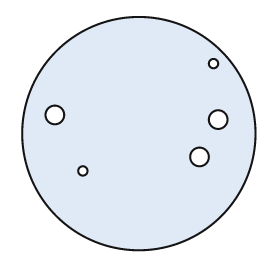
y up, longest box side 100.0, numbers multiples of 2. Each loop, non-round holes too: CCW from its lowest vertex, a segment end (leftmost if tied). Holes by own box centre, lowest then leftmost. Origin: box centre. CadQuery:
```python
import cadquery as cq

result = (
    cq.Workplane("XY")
    .moveTo(0.0, 0.0)
    .circle(50.0)
    .moveTo(-24.0, -16.0)
    .circle(2.0)
    .moveTo(26.0, -10.0)
    .circle(4.0)
    .moveTo(34.0, 6.0)
    .circle(4.0)
    .moveTo(-36.0, 8.0)
    .circle(4.0)
    .moveTo(32.0, 30.0)
    .circle(2.0)
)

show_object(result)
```